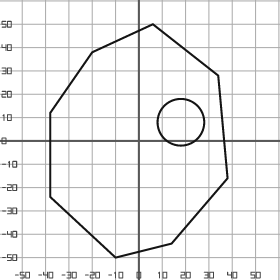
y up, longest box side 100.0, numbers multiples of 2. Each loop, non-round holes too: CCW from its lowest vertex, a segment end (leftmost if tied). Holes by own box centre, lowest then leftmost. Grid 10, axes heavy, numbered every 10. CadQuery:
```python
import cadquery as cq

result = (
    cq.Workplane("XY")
    .moveTo(-10.0, -50.0)
    .lineTo(14.0, -44.0)
    .lineTo(38.0, -16.0)
    .lineTo(34.0, 28.0)
    .lineTo(6.0, 50.0)
    .lineTo(-20.0, 38.0)
    .lineTo(-38.0, 12.0)
    .lineTo(-38.0, -24.0)
    .close()
    .moveTo(18.0, 8.0)
    .circle(10.0)
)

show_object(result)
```